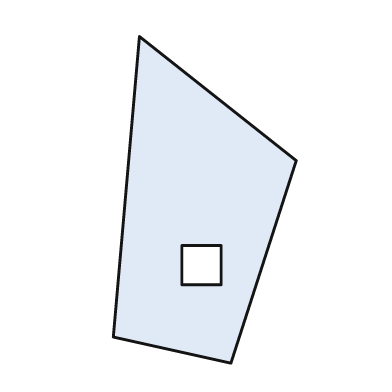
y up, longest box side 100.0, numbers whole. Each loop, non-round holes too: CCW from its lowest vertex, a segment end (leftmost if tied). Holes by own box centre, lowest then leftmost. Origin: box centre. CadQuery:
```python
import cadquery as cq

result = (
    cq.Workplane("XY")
    .moveTo(8.0, -50.0)
    .lineTo(28.0, 12.0)
    .lineTo(-20.0, 50.0)
    .lineTo(-28.0, -42.0)
    .close()
    .moveTo(-7.0, -26.0)
    .lineTo(5.0, -26.0)
    .lineTo(5.0, -14.0)
    .lineTo(-7.0, -14.0)
    .close()
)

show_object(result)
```